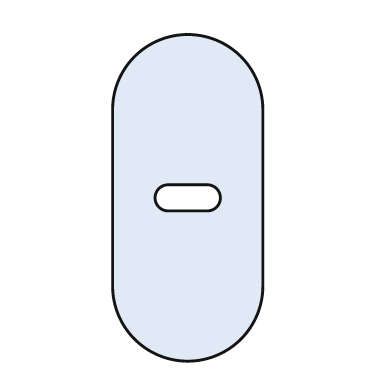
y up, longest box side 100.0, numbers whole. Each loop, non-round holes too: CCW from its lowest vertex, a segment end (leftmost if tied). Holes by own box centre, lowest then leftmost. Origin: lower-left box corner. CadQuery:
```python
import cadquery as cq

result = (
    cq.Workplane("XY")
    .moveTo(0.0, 23.0)
    .threePointArc((23.0, 0.0), (46.0, 23.0))
    .lineTo(46.0, 77.0)
    .threePointArc((23.0, 100.0), (0.0, 77.0))
    .close()
    .moveTo(17.0, 46.0)
    .lineTo(29.0, 46.0)
    .threePointArc((33.0, 50.0), (29.0, 54.0))
    .lineTo(17.0, 54.0)
    .threePointArc((13.0, 50.0), (17.0, 46.0))
    .close()
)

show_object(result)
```